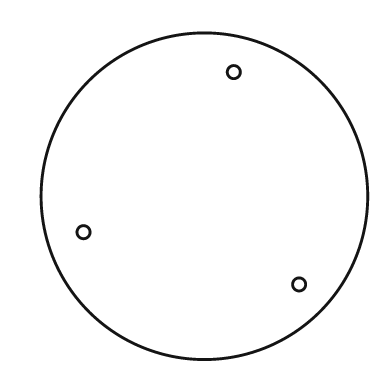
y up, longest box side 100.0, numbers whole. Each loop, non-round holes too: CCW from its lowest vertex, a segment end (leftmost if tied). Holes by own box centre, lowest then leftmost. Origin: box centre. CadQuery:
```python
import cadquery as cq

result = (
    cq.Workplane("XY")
    .moveTo(0.0, 0.0)
    .circle(50.0)
    .moveTo(29.0, -27.0)
    .circle(2.0)
    .moveTo(-37.0, -11.0)
    .circle(2.0)
    .moveTo(9.0, 38.0)
    .circle(2.0)
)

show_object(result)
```